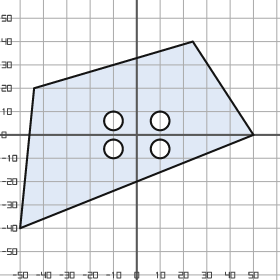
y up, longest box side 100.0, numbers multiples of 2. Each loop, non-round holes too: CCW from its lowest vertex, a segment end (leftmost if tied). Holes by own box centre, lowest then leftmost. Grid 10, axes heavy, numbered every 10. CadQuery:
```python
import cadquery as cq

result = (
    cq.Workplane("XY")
    .moveTo(-50.0, -40.0)
    .lineTo(50.0, 0.0)
    .lineTo(24.0, 40.0)
    .lineTo(-44.0, 20.0)
    .close()
    .moveTo(-10.0, -6.0)
    .circle(4.0)
    .moveTo(10.0, -6.0)
    .circle(4.0)
    .moveTo(-10.0, 6.0)
    .circle(4.0)
    .moveTo(10.0, 6.0)
    .circle(4.0)
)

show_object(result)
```